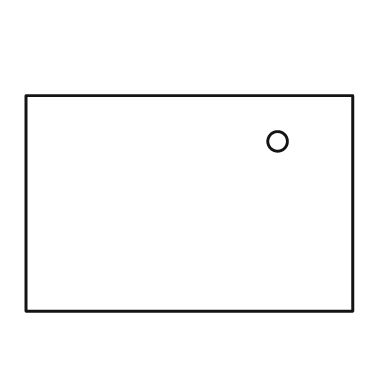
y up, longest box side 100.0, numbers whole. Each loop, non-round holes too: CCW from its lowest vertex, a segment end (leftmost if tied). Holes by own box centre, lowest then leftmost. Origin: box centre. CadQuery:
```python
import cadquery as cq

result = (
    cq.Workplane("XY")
    .moveTo(-50.0, -33.0)
    .lineTo(50.0, -33.0)
    .lineTo(50.0, 33.0)
    .lineTo(-50.0, 33.0)
    .close()
    .moveTo(27.0, 19.0)
    .circle(3.0)
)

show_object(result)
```